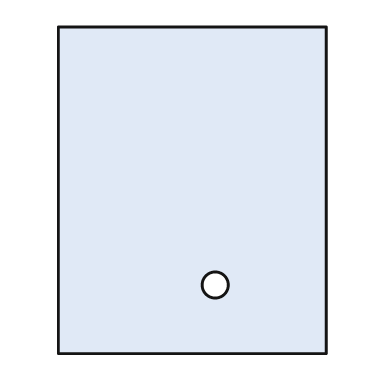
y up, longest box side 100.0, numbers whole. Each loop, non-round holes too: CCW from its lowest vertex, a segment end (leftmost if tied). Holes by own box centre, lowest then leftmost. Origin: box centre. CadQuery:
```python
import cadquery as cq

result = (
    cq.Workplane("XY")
    .moveTo(-41.0, -50.0)
    .lineTo(41.0, -50.0)
    .lineTo(41.0, 50.0)
    .lineTo(-41.0, 50.0)
    .close()
    .moveTo(7.0, -29.0)
    .circle(4.0)
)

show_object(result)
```